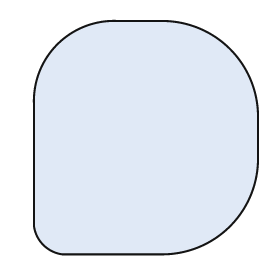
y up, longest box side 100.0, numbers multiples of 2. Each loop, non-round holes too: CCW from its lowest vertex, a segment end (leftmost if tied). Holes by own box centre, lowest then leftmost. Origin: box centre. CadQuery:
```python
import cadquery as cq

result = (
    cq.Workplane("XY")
    .moveTo(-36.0, -50.0)
    .lineTo(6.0, -50.0)
    .threePointArc((36.0, -38.0), (48.0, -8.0))
    .lineTo(48.0, 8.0)
    .threePointArc((36.0, 38.0), (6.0, 50.0))
    .lineTo(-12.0, 50.0)
    .threePointArc((-38.0, 40.0), (-48.0, 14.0))
    .lineTo(-48.0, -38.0)
    .threePointArc((-44.0, -46.0), (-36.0, -50.0))
    .close()
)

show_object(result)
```